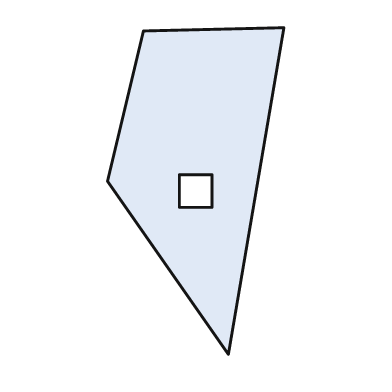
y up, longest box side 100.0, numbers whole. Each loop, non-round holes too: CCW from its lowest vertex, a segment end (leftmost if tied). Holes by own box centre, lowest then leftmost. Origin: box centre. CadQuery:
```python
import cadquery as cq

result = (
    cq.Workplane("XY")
    .moveTo(10.0, -50.0)
    .lineTo(27.0, 50.0)
    .lineTo(-16.0, 49.0)
    .lineTo(-27.0, 3.0)
    .close()
    .moveTo(-5.0, -5.0)
    .lineTo(5.0, -5.0)
    .lineTo(5.0, 5.0)
    .lineTo(-5.0, 5.0)
    .close()
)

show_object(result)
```